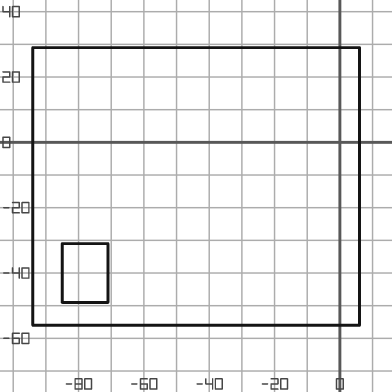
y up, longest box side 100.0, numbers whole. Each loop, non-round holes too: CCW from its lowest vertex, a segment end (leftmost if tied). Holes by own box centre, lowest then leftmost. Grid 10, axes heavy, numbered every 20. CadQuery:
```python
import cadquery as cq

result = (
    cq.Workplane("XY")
    .moveTo(-94.0, -56.0)
    .lineTo(6.0, -56.0)
    .lineTo(6.0, 29.0)
    .lineTo(-94.0, 29.0)
    .close()
    .moveTo(-85.0, -49.0)
    .lineTo(-71.0, -49.0)
    .lineTo(-71.0, -31.0)
    .lineTo(-85.0, -31.0)
    .close()
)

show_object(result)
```